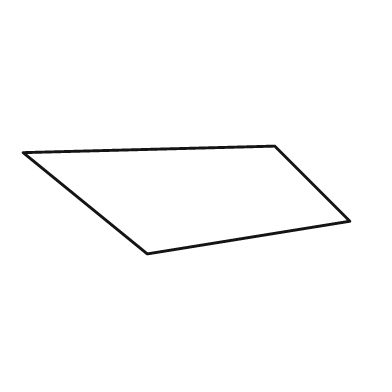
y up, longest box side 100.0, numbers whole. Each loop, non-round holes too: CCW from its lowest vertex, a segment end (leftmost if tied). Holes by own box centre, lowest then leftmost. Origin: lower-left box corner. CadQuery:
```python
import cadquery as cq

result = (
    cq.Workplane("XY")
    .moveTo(38.0, 0.0)
    .lineTo(100.0, 10.0)
    .lineTo(77.0, 33.0)
    .lineTo(0.0, 31.0)
    .close()
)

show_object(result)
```